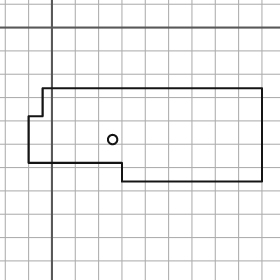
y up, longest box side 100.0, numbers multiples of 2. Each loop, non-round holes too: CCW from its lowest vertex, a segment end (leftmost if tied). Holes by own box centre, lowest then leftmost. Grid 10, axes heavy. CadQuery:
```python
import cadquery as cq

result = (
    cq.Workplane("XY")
    .moveTo(30.0, -66.0)
    .lineTo(90.0, -66.0)
    .lineTo(90.0, -26.0)
    .lineTo(-4.0, -26.0)
    .lineTo(-4.0, -38.0)
    .lineTo(-10.0, -38.0)
    .lineTo(-10.0, -58.0)
    .lineTo(30.0, -58.0)
    .close()
    .moveTo(26.0, -48.0)
    .circle(2.0)
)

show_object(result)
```